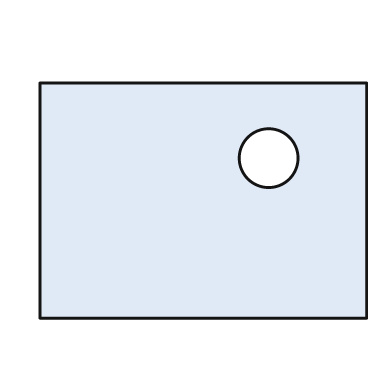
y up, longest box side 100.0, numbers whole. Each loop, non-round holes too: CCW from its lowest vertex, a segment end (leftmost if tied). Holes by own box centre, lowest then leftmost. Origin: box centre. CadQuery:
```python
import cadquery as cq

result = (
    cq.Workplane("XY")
    .moveTo(-50.0, -36.0)
    .lineTo(50.0, -36.0)
    .lineTo(50.0, 36.0)
    .lineTo(-50.0, 36.0)
    .close()
    .moveTo(20.0, 13.0)
    .circle(9.0)
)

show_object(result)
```